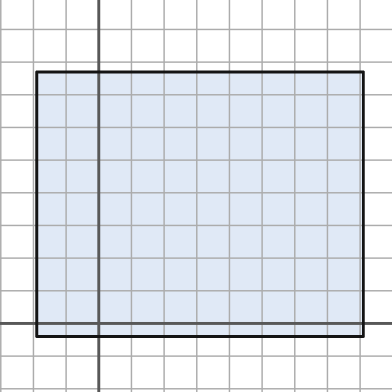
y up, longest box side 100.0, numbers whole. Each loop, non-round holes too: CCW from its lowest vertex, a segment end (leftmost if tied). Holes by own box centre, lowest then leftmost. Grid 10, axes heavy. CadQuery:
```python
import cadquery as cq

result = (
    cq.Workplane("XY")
    .moveTo(-19.0, -4.0)
    .lineTo(81.0, -4.0)
    .lineTo(81.0, 77.0)
    .lineTo(-19.0, 77.0)
    .close()
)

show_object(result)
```